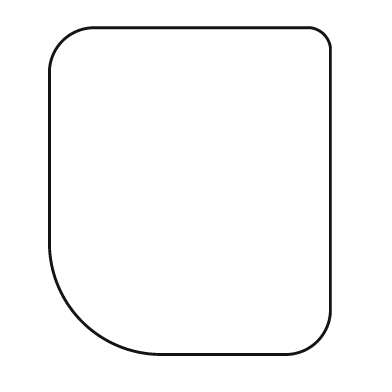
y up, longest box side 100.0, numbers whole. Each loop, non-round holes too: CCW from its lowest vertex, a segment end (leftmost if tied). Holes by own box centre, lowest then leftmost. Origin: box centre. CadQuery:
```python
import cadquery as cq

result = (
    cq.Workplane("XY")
    .moveTo(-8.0, -50.0)
    .lineTo(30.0, -50.0)
    .threePointArc((39.0, -46.0), (43.0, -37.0))
    .lineTo(43.0, 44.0)
    .threePointArc((41.0, 48.0), (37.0, 50.0))
    .lineTo(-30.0, 50.0)
    .threePointArc((-39.0, 46.0), (-43.0, 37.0))
    .lineTo(-43.0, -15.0)
    .threePointArc((-33.0, -40.0), (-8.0, -50.0))
    .close()
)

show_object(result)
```